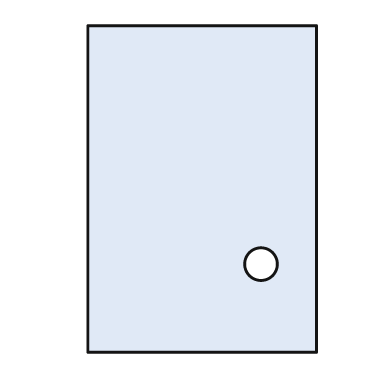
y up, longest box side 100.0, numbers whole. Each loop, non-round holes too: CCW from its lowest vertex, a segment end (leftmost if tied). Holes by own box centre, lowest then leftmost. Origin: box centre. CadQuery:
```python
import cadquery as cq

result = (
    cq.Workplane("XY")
    .moveTo(-35.0, -50.0)
    .lineTo(35.0, -50.0)
    .lineTo(35.0, 50.0)
    .lineTo(-35.0, 50.0)
    .close()
    .moveTo(18.0, -23.0)
    .circle(5.0)
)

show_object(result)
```